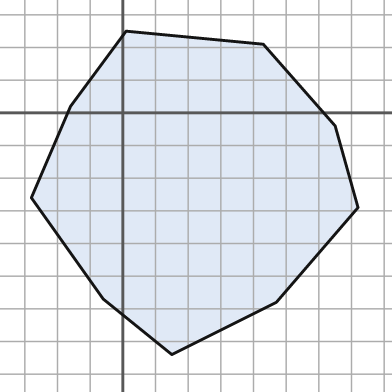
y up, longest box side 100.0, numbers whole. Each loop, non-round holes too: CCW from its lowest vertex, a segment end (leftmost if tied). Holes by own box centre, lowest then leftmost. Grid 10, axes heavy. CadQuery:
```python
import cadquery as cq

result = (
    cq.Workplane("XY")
    .moveTo(15.0, -74.0)
    .lineTo(47.0, -58.0)
    .lineTo(72.0, -29.0)
    .lineTo(65.0, -4.0)
    .lineTo(43.0, 21.0)
    .lineTo(1.0, 25.0)
    .lineTo(-16.0, 2.0)
    .lineTo(-28.0, -26.0)
    .lineTo(-6.0, -57.0)
    .close()
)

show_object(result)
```